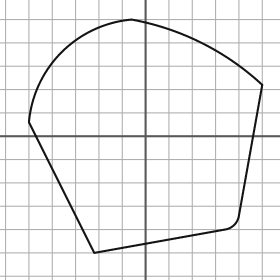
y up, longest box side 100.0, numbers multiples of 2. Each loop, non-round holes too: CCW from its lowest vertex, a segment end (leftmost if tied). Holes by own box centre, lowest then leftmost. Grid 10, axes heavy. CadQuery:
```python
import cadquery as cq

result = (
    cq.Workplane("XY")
    .moveTo(-22.0, -50.0)
    .lineTo(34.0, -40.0)
    .threePointArc((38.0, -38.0), (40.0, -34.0))
    .lineTo(50.0, 22.0)
    .threePointArc((24.0, 40.0), (-6.0, 50.0))
    .threePointArc((-36.0, 36.0), (-50.0, 6.0))
    .close()
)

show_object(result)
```